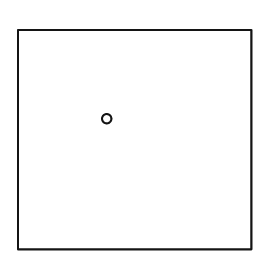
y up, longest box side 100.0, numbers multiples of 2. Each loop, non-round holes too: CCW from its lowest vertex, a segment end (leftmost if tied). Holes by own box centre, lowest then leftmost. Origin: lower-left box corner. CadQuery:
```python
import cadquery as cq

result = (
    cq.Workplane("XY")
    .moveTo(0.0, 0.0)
    .lineTo(100.0, 0.0)
    .lineTo(100.0, 94.0)
    .lineTo(0.0, 94.0)
    .close()
    .moveTo(38.0, 56.0)
    .circle(2.0)
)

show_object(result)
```